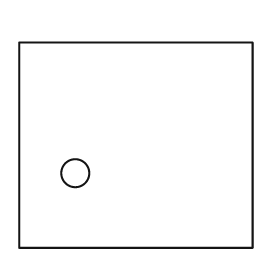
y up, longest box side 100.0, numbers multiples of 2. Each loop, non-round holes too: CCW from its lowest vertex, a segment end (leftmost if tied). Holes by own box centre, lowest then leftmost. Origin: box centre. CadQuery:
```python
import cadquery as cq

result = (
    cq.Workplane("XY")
    .moveTo(-50.0, -44.0)
    .lineTo(50.0, -44.0)
    .lineTo(50.0, 44.0)
    .lineTo(-50.0, 44.0)
    .close()
    .moveTo(-26.0, -12.0)
    .circle(6.0)
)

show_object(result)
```